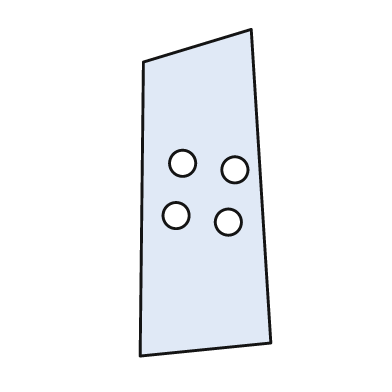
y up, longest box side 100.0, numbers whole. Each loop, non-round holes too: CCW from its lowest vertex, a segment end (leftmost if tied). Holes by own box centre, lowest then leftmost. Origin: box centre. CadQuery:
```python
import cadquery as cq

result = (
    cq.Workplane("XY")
    .moveTo(-20.0, -50.0)
    .lineTo(20.0, -46.0)
    .lineTo(14.0, 50.0)
    .lineTo(-19.0, 40.0)
    .close()
    .moveTo(7.0, -9.0)
    .circle(4.0)
    .moveTo(-9.0, -7.0)
    .circle(4.0)
    .moveTo(9.0, 7.0)
    .circle(4.0)
    .moveTo(-7.0, 9.0)
    .circle(4.0)
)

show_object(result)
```